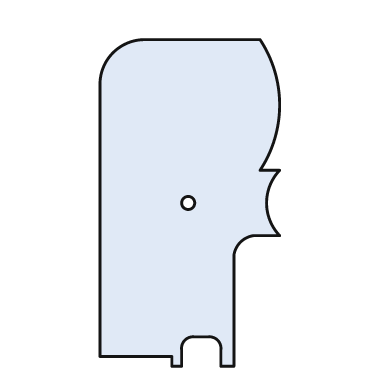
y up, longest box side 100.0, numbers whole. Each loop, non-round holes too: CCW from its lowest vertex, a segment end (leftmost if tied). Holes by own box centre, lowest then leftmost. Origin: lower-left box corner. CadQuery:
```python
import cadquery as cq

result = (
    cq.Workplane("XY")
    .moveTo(22.0, 0.0)
    .lineTo(25.0, 0.0)
    .lineTo(25.0, 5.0)
    .threePointArc((26.0, 8.0), (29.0, 9.0))
    .lineTo(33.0, 9.0)
    .threePointArc((36.0, 8.0), (37.0, 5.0))
    .lineTo(37.0, 0.0)
    .lineTo(41.0, 0.0)
    .lineTo(41.0, 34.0)
    .threePointArc((43.0, 38.0), (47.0, 40.0))
    .lineTo(55.0, 40.0)
    .threePointArc((51.0, 50.0), (55.0, 60.0))
    .lineTo(49.0, 60.0)
    .threePointArc((55.0, 80.0), (49.0, 100.0))
    .lineTo(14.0, 100.0)
    .threePointArc((4.0, 96.0), (0.0, 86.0))
    .lineTo(0.0, 3.0)
    .lineTo(22.0, 3.0)
    .close()
    .moveTo(27.0, 50.0)
    .circle(2.0)
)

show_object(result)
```